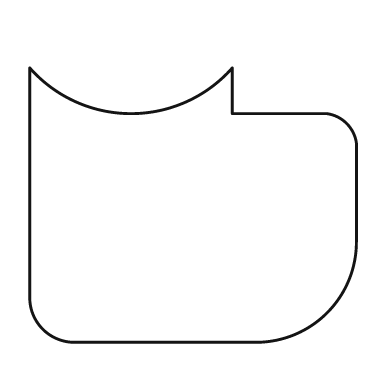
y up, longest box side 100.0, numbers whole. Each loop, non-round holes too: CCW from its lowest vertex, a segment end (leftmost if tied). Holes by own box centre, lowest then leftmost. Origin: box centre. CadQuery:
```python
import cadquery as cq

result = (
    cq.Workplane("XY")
    .moveTo(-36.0, -42.0)
    .lineTo(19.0, -42.0)
    .threePointArc((41.0, -33.0), (50.0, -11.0))
    .lineTo(50.0, 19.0)
    .threePointArc((47.0, 25.0), (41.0, 28.0))
    .lineTo(12.0, 28.0)
    .lineTo(12.0, 42.0)
    .threePointArc((-19.0, 28.0), (-50.0, 42.0))
    .lineTo(-50.0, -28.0)
    .threePointArc((-46.0, -38.0), (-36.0, -42.0))
    .close()
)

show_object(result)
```